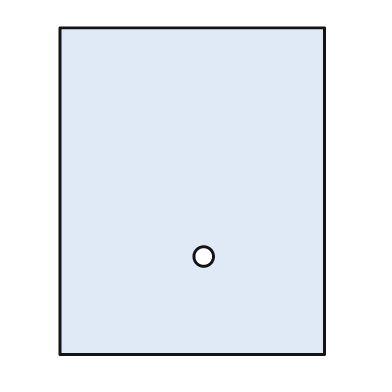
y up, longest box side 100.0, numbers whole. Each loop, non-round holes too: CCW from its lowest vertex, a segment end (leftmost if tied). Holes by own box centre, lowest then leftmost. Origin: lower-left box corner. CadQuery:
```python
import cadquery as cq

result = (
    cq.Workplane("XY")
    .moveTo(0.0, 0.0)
    .lineTo(81.0, 0.0)
    .lineTo(81.0, 100.0)
    .lineTo(0.0, 100.0)
    .close()
    .moveTo(44.0, 30.0)
    .circle(3.0)
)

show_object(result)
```